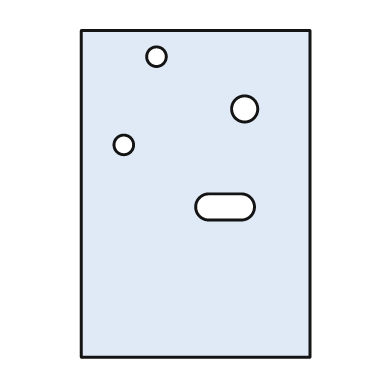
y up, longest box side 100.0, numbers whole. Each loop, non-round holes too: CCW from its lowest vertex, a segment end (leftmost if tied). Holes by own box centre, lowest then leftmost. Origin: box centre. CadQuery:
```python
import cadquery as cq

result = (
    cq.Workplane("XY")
    .moveTo(-35.0, -50.0)
    .lineTo(35.0, -50.0)
    .lineTo(35.0, 50.0)
    .lineTo(-35.0, 50.0)
    .close()
    .moveTo(4.0, -8.0)
    .lineTo(14.0, -8.0)
    .threePointArc((18.0, -4.0), (14.0, 0.0))
    .lineTo(4.0, 0.0)
    .threePointArc((0.0, -4.0), (4.0, -8.0))
    .close()
    .moveTo(-22.0, 15.0)
    .circle(3.0)
    .moveTo(15.0, 26.0)
    .circle(4.0)
    .moveTo(-12.0, 42.0)
    .circle(3.0)
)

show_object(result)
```